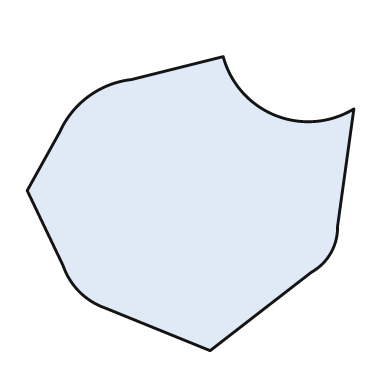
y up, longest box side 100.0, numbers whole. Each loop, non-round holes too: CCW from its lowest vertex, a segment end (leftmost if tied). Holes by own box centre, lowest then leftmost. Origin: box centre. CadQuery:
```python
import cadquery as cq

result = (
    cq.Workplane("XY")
    .moveTo(6.0, -45.0)
    .lineTo(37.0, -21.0)
    .threePointArc((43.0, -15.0), (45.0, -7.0))
    .lineTo(50.0, 29.0)
    .threePointArc((26.0, 27.0), (10.0, 45.0))
    .lineTo(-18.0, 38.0)
    .threePointArc((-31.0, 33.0), (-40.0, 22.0))
    .lineTo(-50.0, 4.0)
    .lineTo(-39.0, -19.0)
    .threePointArc((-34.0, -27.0), (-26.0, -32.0))
    .close()
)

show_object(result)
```